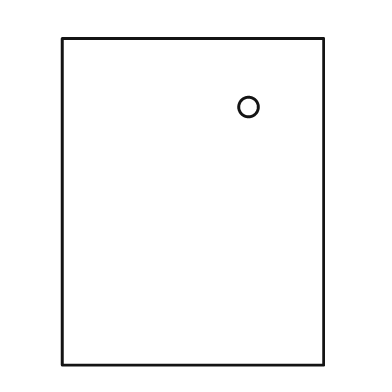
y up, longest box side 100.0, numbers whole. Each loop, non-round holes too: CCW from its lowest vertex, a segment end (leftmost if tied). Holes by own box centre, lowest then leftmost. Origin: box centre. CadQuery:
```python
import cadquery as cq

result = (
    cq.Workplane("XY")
    .moveTo(-40.0, -50.0)
    .lineTo(40.0, -50.0)
    .lineTo(40.0, 50.0)
    .lineTo(-40.0, 50.0)
    .close()
    .moveTo(17.0, 29.0)
    .circle(3.0)
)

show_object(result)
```